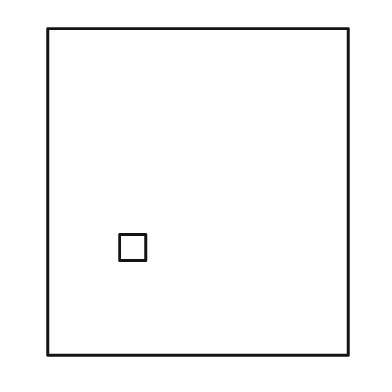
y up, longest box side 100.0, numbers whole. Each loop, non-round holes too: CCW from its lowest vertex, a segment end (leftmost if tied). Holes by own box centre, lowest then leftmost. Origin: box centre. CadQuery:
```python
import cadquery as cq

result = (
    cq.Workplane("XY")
    .moveTo(-46.0, -50.0)
    .lineTo(46.0, -50.0)
    .lineTo(46.0, 50.0)
    .lineTo(-46.0, 50.0)
    .close()
    .moveTo(-24.0, -21.0)
    .lineTo(-16.0, -21.0)
    .lineTo(-16.0, -13.0)
    .lineTo(-24.0, -13.0)
    .close()
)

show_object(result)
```